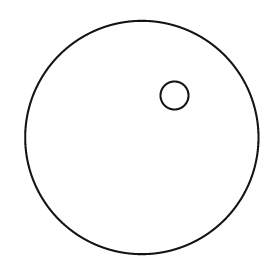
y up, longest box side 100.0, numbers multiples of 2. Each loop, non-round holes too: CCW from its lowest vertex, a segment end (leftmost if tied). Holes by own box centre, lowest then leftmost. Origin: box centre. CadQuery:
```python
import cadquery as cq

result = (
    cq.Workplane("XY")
    .moveTo(0.0, 0.0)
    .circle(50.0)
    .moveTo(14.0, 18.0)
    .circle(6.0)
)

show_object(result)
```